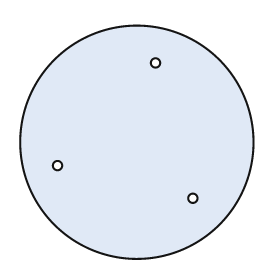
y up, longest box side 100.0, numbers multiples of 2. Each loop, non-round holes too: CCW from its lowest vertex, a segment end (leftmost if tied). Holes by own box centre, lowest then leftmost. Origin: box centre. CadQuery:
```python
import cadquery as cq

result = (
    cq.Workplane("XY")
    .moveTo(0.0, 0.0)
    .circle(50.0)
    .moveTo(24.0, -24.0)
    .circle(2.0)
    .moveTo(-34.0, -10.0)
    .circle(2.0)
    .moveTo(8.0, 34.0)
    .circle(2.0)
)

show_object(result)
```